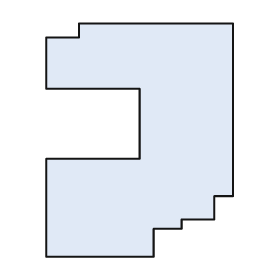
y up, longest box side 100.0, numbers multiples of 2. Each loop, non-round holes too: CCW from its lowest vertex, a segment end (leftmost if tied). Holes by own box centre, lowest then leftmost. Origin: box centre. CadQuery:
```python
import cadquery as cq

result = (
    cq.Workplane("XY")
    .moveTo(-40.0, -50.0)
    .lineTo(6.0, -50.0)
    .lineTo(6.0, -38.0)
    .lineTo(18.0, -38.0)
    .lineTo(18.0, -34.0)
    .lineTo(32.0, -34.0)
    .lineTo(32.0, -24.0)
    .lineTo(40.0, -24.0)
    .lineTo(40.0, 50.0)
    .lineTo(-26.0, 50.0)
    .lineTo(-26.0, 44.0)
    .lineTo(-40.0, 44.0)
    .lineTo(-40.0, 22.0)
    .lineTo(0.0, 22.0)
    .lineTo(0.0, -8.0)
    .lineTo(-40.0, -8.0)
    .close()
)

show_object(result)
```